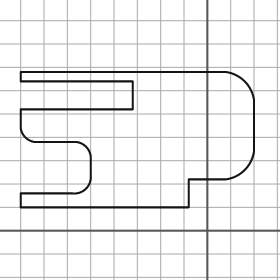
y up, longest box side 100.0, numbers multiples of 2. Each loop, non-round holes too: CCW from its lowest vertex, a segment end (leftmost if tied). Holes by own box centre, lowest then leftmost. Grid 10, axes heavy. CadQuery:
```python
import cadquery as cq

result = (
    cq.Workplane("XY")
    .moveTo(-80.0, 10.0)
    .lineTo(-8.0, 10.0)
    .lineTo(-8.0, 22.0)
    .lineTo(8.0, 22.0)
    .threePointArc((16.0, 26.0), (20.0, 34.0))
    .lineTo(20.0, 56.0)
    .threePointArc((16.0, 64.0), (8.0, 68.0))
    .lineTo(-80.0, 68.0)
    .lineTo(-80.0, 64.0)
    .lineTo(-32.0, 64.0)
    .lineTo(-32.0, 52.0)
    .lineTo(-80.0, 52.0)
    .lineTo(-80.0, 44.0)
    .threePointArc((-78.0, 40.0), (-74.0, 38.0))
    .lineTo(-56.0, 38.0)
    .threePointArc((-52.0, 36.0), (-50.0, 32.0))
    .lineTo(-50.0, 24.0)
    .threePointArc((-52.0, 18.0), (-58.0, 16.0))
    .lineTo(-80.0, 16.0)
    .close()
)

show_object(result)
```